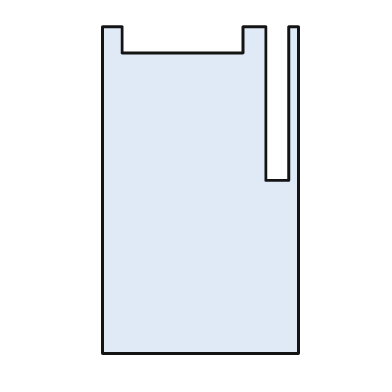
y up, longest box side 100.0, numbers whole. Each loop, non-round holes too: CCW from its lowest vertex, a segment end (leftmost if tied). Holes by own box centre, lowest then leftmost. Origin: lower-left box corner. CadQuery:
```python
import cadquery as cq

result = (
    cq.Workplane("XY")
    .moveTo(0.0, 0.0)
    .lineTo(60.0, 0.0)
    .lineTo(60.0, 100.0)
    .lineTo(57.0, 100.0)
    .lineTo(57.0, 53.0)
    .lineTo(50.0, 53.0)
    .lineTo(50.0, 100.0)
    .lineTo(43.0, 100.0)
    .lineTo(43.0, 92.0)
    .lineTo(6.0, 92.0)
    .lineTo(6.0, 100.0)
    .lineTo(0.0, 100.0)
    .close()
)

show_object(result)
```